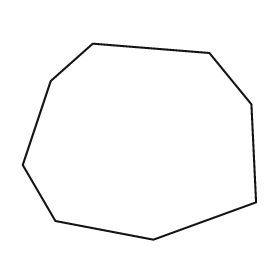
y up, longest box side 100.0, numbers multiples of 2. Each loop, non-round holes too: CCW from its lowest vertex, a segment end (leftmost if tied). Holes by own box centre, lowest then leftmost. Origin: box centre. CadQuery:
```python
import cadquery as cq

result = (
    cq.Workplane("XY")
    .moveTo(6.0, -42.0)
    .lineTo(50.0, -26.0)
    .lineTo(48.0, 16.0)
    .lineTo(30.0, 38.0)
    .lineTo(-20.0, 42.0)
    .lineTo(-38.0, 26.0)
    .lineTo(-50.0, -10.0)
    .lineTo(-36.0, -34.0)
    .close()
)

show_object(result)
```